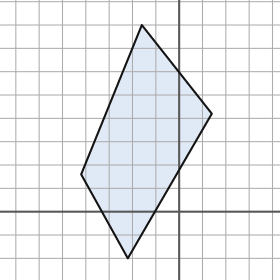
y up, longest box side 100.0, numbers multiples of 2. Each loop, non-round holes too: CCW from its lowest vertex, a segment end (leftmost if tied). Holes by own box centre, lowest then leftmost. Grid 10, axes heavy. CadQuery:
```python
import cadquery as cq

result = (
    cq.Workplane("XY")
    .moveTo(-22.0, -20.0)
    .lineTo(14.0, 42.0)
    .lineTo(-16.0, 80.0)
    .lineTo(-42.0, 16.0)
    .close()
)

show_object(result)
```